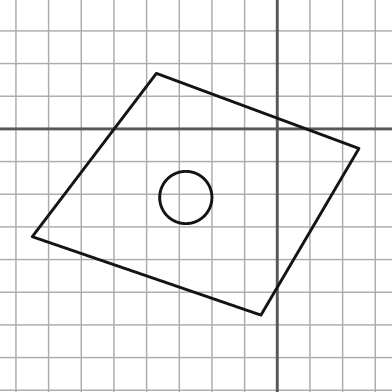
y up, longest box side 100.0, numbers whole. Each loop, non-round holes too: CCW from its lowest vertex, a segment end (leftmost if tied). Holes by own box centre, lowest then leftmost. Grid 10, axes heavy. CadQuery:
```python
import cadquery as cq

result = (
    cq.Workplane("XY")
    .moveTo(-5.0, -57.0)
    .lineTo(25.0, -6.0)
    .lineTo(-37.0, 17.0)
    .lineTo(-75.0, -33.0)
    .close()
    .moveTo(-28.0, -21.0)
    .circle(8.0)
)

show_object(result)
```